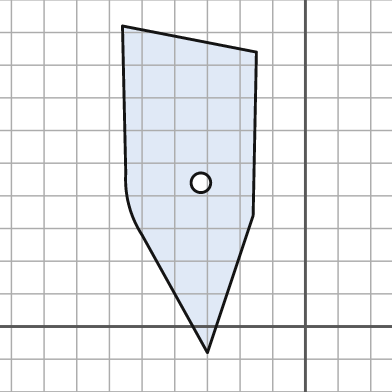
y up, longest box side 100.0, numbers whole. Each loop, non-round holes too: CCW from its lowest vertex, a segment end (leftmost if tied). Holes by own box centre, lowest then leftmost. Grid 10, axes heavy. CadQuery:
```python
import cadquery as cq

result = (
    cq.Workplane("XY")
    .moveTo(-30.0, -8.0)
    .lineTo(-16.0, 34.0)
    .lineTo(-15.0, 84.0)
    .lineTo(-56.0, 92.0)
    .lineTo(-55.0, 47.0)
    .threePointArc((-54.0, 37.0), (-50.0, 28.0))
    .close()
    .moveTo(-32.0, 44.0)
    .circle(3.0)
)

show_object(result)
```